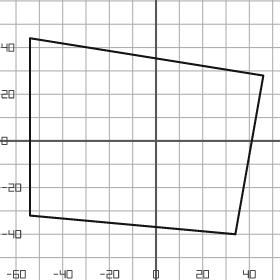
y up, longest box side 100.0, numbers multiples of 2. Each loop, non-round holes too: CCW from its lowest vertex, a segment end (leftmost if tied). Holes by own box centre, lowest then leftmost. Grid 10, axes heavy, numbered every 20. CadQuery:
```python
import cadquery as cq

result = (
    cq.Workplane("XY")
    .moveTo(34.0, -40.0)
    .lineTo(46.0, 28.0)
    .lineTo(-54.0, 44.0)
    .lineTo(-54.0, -32.0)
    .close()
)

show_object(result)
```